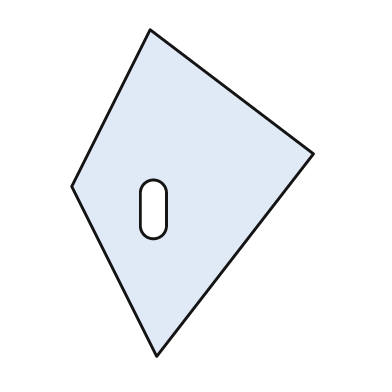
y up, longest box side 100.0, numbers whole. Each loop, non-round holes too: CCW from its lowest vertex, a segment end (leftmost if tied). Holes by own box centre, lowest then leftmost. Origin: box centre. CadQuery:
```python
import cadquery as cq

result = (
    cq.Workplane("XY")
    .moveTo(-11.0, -50.0)
    .lineTo(37.0, 12.0)
    .lineTo(-13.0, 50.0)
    .lineTo(-37.0, 2.0)
    .close()
    .moveTo(-16.0, -10.0)
    .threePointArc((-12.0, -14.0), (-8.0, -10.0))
    .lineTo(-8.0, 0.0)
    .threePointArc((-12.0, 4.0), (-16.0, 0.0))
    .close()
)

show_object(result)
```